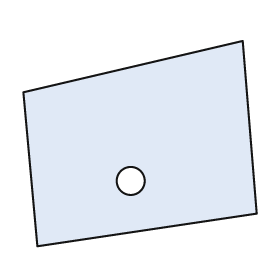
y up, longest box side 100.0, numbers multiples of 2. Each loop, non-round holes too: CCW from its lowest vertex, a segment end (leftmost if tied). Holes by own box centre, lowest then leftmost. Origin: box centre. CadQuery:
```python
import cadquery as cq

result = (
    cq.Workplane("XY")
    .moveTo(-44.0, -44.0)
    .lineTo(50.0, -30.0)
    .lineTo(44.0, 44.0)
    .lineTo(-50.0, 22.0)
    .close()
    .moveTo(-4.0, -16.0)
    .circle(6.0)
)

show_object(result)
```